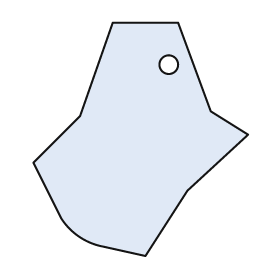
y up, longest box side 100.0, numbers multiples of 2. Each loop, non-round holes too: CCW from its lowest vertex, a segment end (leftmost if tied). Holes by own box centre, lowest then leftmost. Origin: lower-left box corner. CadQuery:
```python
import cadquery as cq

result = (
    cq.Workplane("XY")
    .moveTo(48.0, 0.0)
    .lineTo(66.0, 28.0)
    .lineTo(92.0, 52.0)
    .lineTo(76.0, 62.0)
    .lineTo(62.0, 100.0)
    .lineTo(34.0, 100.0)
    .lineTo(20.0, 60.0)
    .lineTo(0.0, 40.0)
    .lineTo(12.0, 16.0)
    .threePointArc((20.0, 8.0), (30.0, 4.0))
    .close()
    .moveTo(58.0, 82.0)
    .circle(4.0)
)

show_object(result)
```